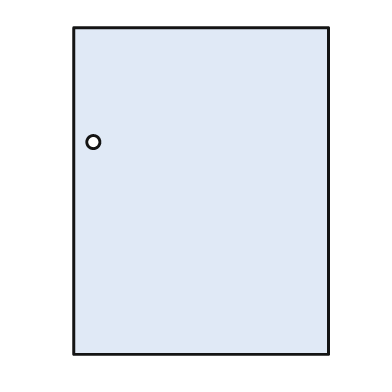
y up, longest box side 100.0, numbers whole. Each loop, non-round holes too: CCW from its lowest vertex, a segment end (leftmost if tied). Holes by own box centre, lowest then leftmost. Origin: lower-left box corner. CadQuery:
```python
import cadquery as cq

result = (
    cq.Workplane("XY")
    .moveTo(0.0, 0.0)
    .lineTo(78.0, 0.0)
    .lineTo(78.0, 100.0)
    .lineTo(0.0, 100.0)
    .close()
    .moveTo(6.0, 65.0)
    .circle(2.0)
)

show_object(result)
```